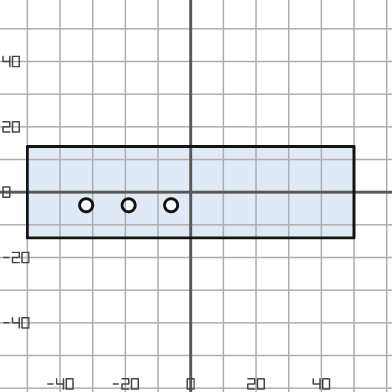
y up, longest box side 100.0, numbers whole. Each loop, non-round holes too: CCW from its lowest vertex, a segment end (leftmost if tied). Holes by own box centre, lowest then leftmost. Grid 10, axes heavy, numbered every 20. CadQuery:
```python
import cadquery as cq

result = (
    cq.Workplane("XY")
    .moveTo(-50.0, -14.0)
    .lineTo(50.0, -14.0)
    .lineTo(50.0, 14.0)
    .lineTo(-50.0, 14.0)
    .close()
    .moveTo(-32.0, -4.0)
    .circle(2.0)
    .moveTo(-19.0, -4.0)
    .circle(2.0)
    .moveTo(-6.0, -4.0)
    .circle(2.0)
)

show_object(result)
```